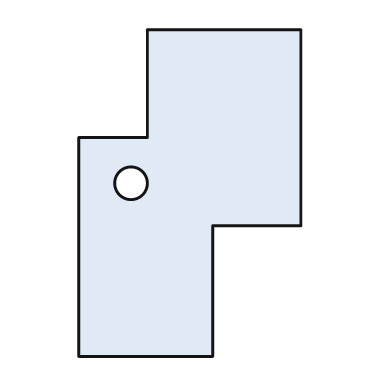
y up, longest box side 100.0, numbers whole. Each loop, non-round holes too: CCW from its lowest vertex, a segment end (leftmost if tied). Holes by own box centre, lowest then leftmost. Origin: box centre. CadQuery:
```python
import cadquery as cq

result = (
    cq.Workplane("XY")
    .moveTo(-34.0, -50.0)
    .lineTo(7.0, -50.0)
    .lineTo(7.0, -10.0)
    .lineTo(34.0, -10.0)
    .lineTo(34.0, 50.0)
    .lineTo(-13.0, 50.0)
    .lineTo(-13.0, 17.0)
    .lineTo(-34.0, 17.0)
    .close()
    .moveTo(-18.0, 3.0)
    .circle(5.0)
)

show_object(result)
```